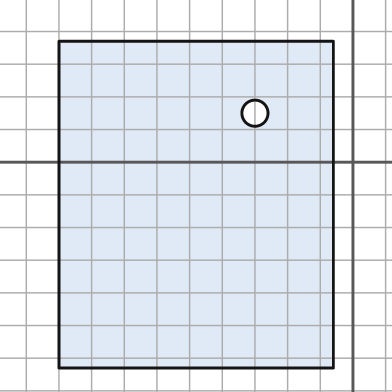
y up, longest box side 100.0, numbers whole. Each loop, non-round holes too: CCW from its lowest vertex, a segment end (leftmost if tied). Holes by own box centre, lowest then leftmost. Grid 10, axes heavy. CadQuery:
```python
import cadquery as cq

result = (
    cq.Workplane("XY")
    .moveTo(-90.0, -63.0)
    .lineTo(-6.0, -63.0)
    .lineTo(-6.0, 37.0)
    .lineTo(-90.0, 37.0)
    .close()
    .moveTo(-30.0, 15.0)
    .circle(4.0)
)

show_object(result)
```